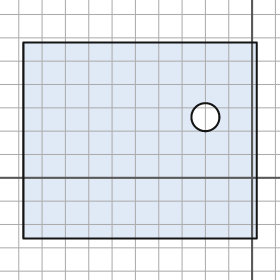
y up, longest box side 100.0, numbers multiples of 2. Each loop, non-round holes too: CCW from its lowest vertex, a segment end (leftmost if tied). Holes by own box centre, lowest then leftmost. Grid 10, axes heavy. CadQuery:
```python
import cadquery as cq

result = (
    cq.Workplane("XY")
    .moveTo(-98.0, -26.0)
    .lineTo(2.0, -26.0)
    .lineTo(2.0, 58.0)
    .lineTo(-98.0, 58.0)
    .close()
    .moveTo(-20.0, 26.0)
    .circle(6.0)
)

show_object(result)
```